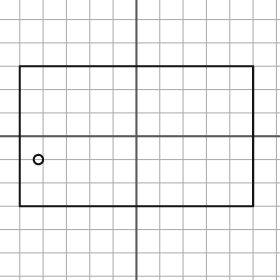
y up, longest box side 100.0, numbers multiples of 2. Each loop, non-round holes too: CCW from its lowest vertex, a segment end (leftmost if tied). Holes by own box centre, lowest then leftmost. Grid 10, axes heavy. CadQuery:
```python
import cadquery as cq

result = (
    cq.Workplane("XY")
    .moveTo(-50.0, -30.0)
    .lineTo(50.0, -30.0)
    .lineTo(50.0, 30.0)
    .lineTo(-50.0, 30.0)
    .close()
    .moveTo(-42.0, -10.0)
    .circle(2.0)
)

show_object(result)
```